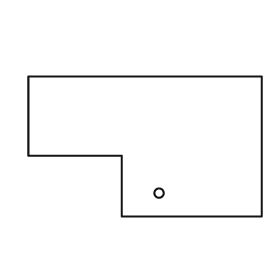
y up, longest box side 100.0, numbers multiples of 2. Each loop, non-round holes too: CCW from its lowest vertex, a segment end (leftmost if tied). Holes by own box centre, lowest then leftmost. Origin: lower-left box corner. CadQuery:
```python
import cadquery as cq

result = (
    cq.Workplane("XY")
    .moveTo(40.0, 0.0)
    .lineTo(100.0, 0.0)
    .lineTo(100.0, 60.0)
    .lineTo(0.0, 60.0)
    .lineTo(0.0, 26.0)
    .lineTo(40.0, 26.0)
    .close()
    .moveTo(56.0, 10.0)
    .circle(2.0)
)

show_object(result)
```